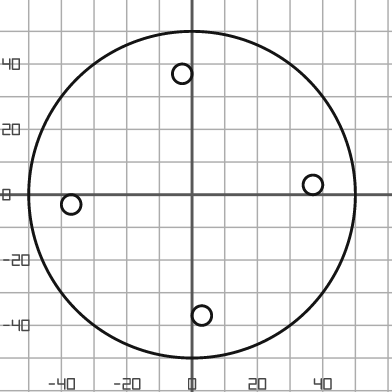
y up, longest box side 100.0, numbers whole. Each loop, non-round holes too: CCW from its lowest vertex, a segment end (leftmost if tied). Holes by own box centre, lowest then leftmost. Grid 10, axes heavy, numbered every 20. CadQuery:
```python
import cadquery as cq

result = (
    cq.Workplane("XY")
    .moveTo(0.0, 0.0)
    .circle(50.0)
    .moveTo(3.0, -37.0)
    .circle(3.0)
    .moveTo(-37.0, -3.0)
    .circle(3.0)
    .moveTo(37.0, 3.0)
    .circle(3.0)
    .moveTo(-3.0, 37.0)
    .circle(3.0)
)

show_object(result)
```